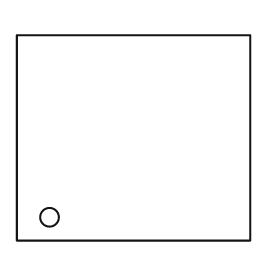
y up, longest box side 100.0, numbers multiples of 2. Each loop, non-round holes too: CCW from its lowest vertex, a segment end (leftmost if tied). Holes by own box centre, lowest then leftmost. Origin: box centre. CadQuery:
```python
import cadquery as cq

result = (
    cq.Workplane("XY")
    .moveTo(-50.0, -44.0)
    .lineTo(50.0, -44.0)
    .lineTo(50.0, 44.0)
    .lineTo(-50.0, 44.0)
    .close()
    .moveTo(-36.0, -34.0)
    .circle(4.0)
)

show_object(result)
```